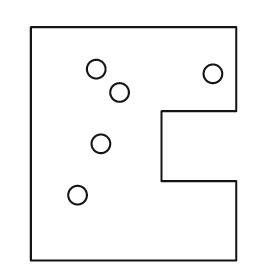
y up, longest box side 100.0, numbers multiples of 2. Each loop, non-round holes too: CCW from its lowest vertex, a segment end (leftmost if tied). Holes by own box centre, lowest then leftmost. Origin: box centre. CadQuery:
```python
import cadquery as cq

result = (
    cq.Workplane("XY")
    .moveTo(-44.0, -50.0)
    .lineTo(44.0, -50.0)
    .lineTo(44.0, -16.0)
    .lineTo(12.0, -16.0)
    .lineTo(12.0, 14.0)
    .lineTo(44.0, 14.0)
    .lineTo(44.0, 50.0)
    .lineTo(-44.0, 50.0)
    .close()
    .moveTo(-24.0, -22.0)
    .circle(4.0)
    .moveTo(-14.0, 0.0)
    .circle(4.0)
    .moveTo(-6.0, 22.0)
    .circle(4.0)
    .moveTo(34.0, 30.0)
    .circle(4.0)
    .moveTo(-16.0, 32.0)
    .circle(4.0)
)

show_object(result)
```